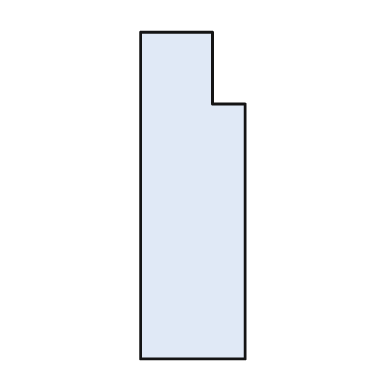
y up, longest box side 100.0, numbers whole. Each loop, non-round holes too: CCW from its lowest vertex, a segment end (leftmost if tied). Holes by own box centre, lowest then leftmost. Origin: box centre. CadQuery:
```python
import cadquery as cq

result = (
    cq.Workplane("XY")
    .moveTo(-16.0, -50.0)
    .lineTo(16.0, -50.0)
    .lineTo(16.0, 28.0)
    .lineTo(6.0, 28.0)
    .lineTo(6.0, 50.0)
    .lineTo(-16.0, 50.0)
    .close()
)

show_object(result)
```